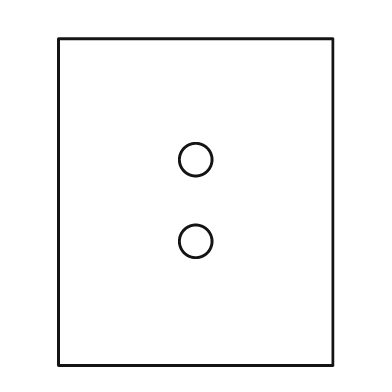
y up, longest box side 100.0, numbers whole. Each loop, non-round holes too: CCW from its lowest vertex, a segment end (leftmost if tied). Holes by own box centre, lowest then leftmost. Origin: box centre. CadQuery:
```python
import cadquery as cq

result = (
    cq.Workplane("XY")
    .moveTo(-42.0, -50.0)
    .lineTo(42.0, -50.0)
    .lineTo(42.0, 50.0)
    .lineTo(-42.0, 50.0)
    .close()
    .moveTo(0.0, -12.0)
    .circle(5.0)
    .moveTo(0.0, 13.0)
    .circle(5.0)
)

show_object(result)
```